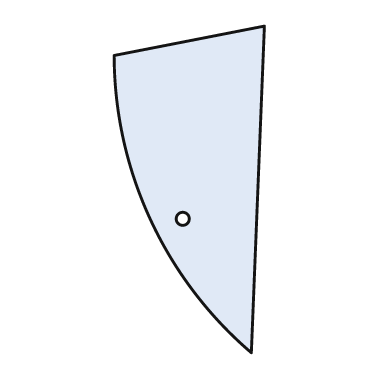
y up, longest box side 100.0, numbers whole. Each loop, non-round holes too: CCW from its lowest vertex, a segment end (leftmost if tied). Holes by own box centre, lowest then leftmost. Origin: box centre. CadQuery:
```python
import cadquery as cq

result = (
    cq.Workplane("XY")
    .moveTo(19.0, -50.0)
    .lineTo(23.0, 50.0)
    .lineTo(-23.0, 41.0)
    .threePointArc((-12.0, -9.0), (19.0, -50.0))
    .close()
    .moveTo(-2.0, -9.0)
    .circle(2.0)
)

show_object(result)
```